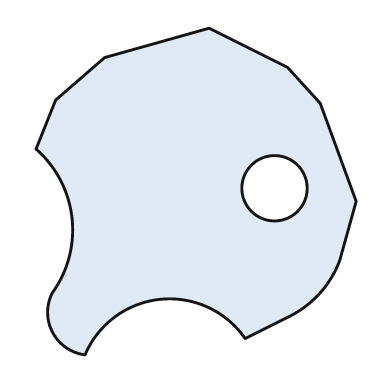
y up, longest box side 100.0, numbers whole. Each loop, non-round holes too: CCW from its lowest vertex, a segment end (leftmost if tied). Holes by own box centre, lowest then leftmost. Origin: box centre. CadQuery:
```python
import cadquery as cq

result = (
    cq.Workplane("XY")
    .moveTo(-34.0, -50.0)
    .threePointArc((-11.0, -33.0), (15.0, -45.0))
    .lineTo(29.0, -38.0)
    .threePointArc((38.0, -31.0), (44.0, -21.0))
    .lineTo(49.0, -3.0)
    .lineTo(38.0, 27.0)
    .lineTo(28.0, 38.0)
    .lineTo(4.0, 50.0)
    .lineTo(-28.0, 41.0)
    .lineTo(-43.0, 28.0)
    .lineTo(-49.0, 13.0)
    .threePointArc((-38.0, -8.0), (-44.0, -31.0))
    .threePointArc((-44.0, -43.0), (-34.0, -50.0))
    .close()
    .moveTo(24.0, 1.0)
    .circle(10.0)
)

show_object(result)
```